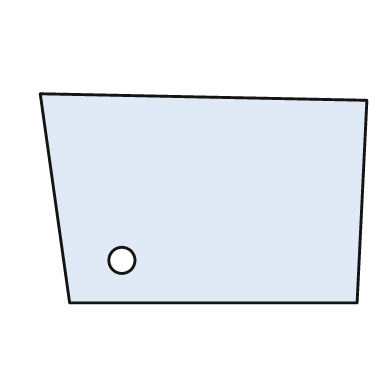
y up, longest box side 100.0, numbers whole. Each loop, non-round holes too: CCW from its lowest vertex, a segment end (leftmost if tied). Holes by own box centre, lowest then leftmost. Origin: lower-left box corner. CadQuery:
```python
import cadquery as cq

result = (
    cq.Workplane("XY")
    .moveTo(9.0, 0.0)
    .lineTo(97.0, 0.0)
    .lineTo(100.0, 62.0)
    .lineTo(0.0, 64.0)
    .close()
    .moveTo(25.0, 13.0)
    .circle(4.0)
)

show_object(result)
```